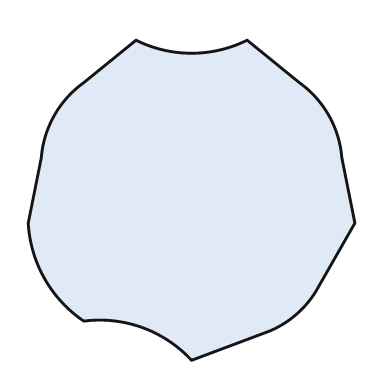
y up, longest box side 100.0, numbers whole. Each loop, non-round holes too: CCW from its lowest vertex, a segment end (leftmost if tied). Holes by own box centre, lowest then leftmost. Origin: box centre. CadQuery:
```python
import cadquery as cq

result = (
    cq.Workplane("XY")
    .moveTo(0.0, -49.0)
    .lineTo(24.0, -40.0)
    .threePointArc((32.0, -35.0), (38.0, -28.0))
    .lineTo(50.0, -7.0)
    .lineTo(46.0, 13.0)
    .threePointArc((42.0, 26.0), (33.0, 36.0))
    .lineTo(17.0, 49.0)
    .threePointArc((0.0, 45.0), (-17.0, 49.0))
    .lineTo(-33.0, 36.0)
    .threePointArc((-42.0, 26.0), (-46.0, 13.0))
    .lineTo(-50.0, -7.0)
    .threePointArc((-45.0, -24.0), (-33.0, -37.0))
    .threePointArc((-15.0, -39.0), (0.0, -49.0))
    .close()
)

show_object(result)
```